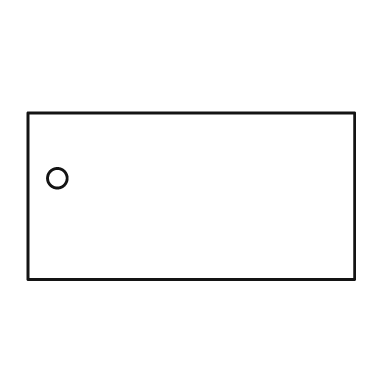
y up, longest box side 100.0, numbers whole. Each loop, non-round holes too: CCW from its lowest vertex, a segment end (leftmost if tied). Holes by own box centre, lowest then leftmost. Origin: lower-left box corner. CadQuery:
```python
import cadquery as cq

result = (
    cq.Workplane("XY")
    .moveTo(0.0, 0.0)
    .lineTo(100.0, 0.0)
    .lineTo(100.0, 51.0)
    .lineTo(0.0, 51.0)
    .close()
    .moveTo(9.0, 31.0)
    .circle(3.0)
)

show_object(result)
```